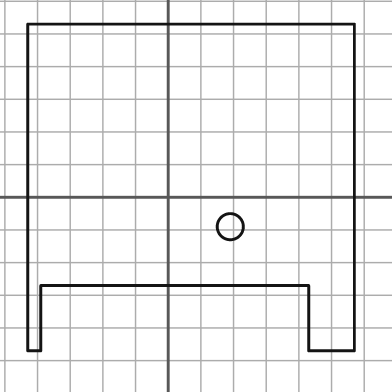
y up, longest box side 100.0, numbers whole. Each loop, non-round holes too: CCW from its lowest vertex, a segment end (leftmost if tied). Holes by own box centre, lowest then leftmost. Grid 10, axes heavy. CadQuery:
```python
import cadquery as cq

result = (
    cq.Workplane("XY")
    .moveTo(-43.0, -47.0)
    .lineTo(-39.0, -47.0)
    .lineTo(-39.0, -27.0)
    .lineTo(43.0, -27.0)
    .lineTo(43.0, -47.0)
    .lineTo(57.0, -47.0)
    .lineTo(57.0, 53.0)
    .lineTo(-43.0, 53.0)
    .close()
    .moveTo(19.0, -9.0)
    .circle(4.0)
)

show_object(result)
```